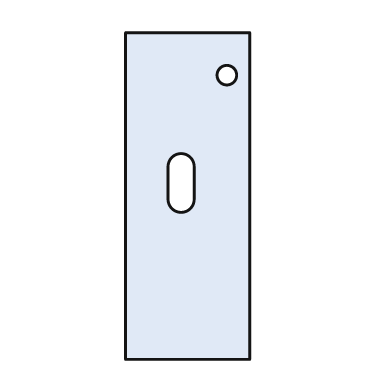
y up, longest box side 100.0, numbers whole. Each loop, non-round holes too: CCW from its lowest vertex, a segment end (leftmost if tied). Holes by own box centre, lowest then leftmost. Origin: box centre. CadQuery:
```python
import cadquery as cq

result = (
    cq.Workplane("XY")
    .moveTo(-19.0, -50.0)
    .lineTo(19.0, -50.0)
    .lineTo(19.0, 50.0)
    .lineTo(-19.0, 50.0)
    .close()
    .moveTo(-6.0, -1.0)
    .threePointArc((-2.0, -5.0), (2.0, -1.0))
    .lineTo(2.0, 9.0)
    .threePointArc((-2.0, 13.0), (-6.0, 9.0))
    .close()
    .moveTo(12.0, 37.0)
    .circle(3.0)
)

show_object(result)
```